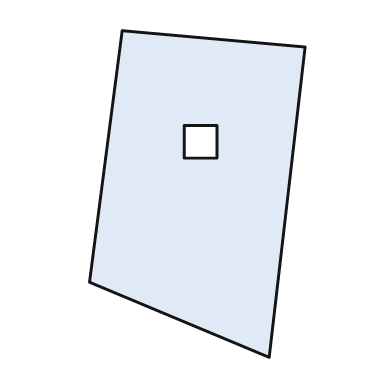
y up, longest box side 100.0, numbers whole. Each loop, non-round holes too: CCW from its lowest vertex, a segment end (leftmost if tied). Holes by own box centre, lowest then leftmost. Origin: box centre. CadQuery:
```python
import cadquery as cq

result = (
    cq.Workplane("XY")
    .moveTo(22.0, -50.0)
    .lineTo(33.0, 45.0)
    .lineTo(-23.0, 50.0)
    .lineTo(-33.0, -27.0)
    .close()
    .moveTo(-4.0, 11.0)
    .lineTo(6.0, 11.0)
    .lineTo(6.0, 21.0)
    .lineTo(-4.0, 21.0)
    .close()
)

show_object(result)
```